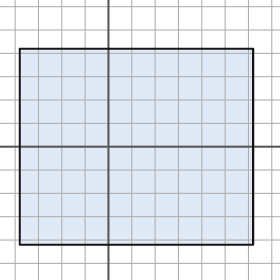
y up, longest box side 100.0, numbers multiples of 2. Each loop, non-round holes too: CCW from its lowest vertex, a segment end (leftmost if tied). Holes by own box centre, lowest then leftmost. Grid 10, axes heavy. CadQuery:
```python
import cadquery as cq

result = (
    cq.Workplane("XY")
    .moveTo(-38.0, -42.0)
    .lineTo(62.0, -42.0)
    .lineTo(62.0, 42.0)
    .lineTo(-38.0, 42.0)
    .close()
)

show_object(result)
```